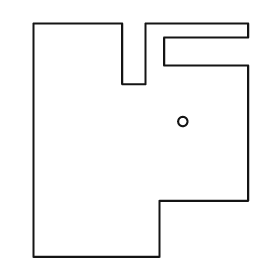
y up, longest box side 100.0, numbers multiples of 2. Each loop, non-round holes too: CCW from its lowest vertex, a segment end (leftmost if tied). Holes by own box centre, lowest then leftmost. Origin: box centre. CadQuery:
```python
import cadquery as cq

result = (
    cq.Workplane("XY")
    .moveTo(-46.0, -50.0)
    .lineTo(8.0, -50.0)
    .lineTo(8.0, -26.0)
    .lineTo(46.0, -26.0)
    .lineTo(46.0, 32.0)
    .lineTo(10.0, 32.0)
    .lineTo(10.0, 44.0)
    .lineTo(46.0, 44.0)
    .lineTo(46.0, 50.0)
    .lineTo(2.0, 50.0)
    .lineTo(2.0, 24.0)
    .lineTo(-8.0, 24.0)
    .lineTo(-8.0, 50.0)
    .lineTo(-46.0, 50.0)
    .close()
    .moveTo(18.0, 8.0)
    .circle(2.0)
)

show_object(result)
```